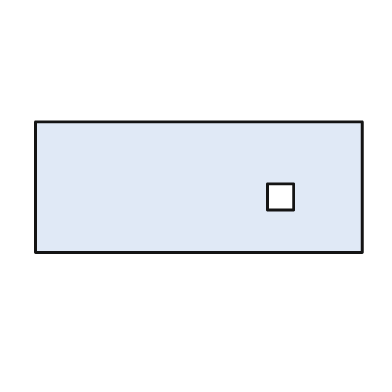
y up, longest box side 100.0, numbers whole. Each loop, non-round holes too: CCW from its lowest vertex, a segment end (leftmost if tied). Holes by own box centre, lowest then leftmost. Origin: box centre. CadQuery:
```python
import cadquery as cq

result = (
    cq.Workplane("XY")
    .moveTo(-50.0, -20.0)
    .lineTo(50.0, -20.0)
    .lineTo(50.0, 20.0)
    .lineTo(-50.0, 20.0)
    .close()
    .moveTo(21.0, -7.0)
    .lineTo(29.0, -7.0)
    .lineTo(29.0, 1.0)
    .lineTo(21.0, 1.0)
    .close()
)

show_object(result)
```